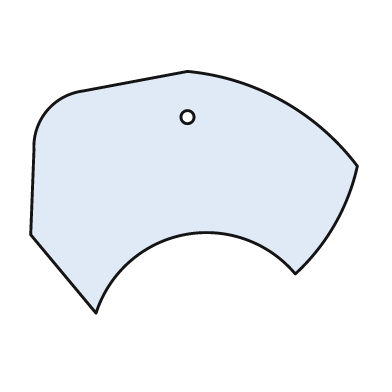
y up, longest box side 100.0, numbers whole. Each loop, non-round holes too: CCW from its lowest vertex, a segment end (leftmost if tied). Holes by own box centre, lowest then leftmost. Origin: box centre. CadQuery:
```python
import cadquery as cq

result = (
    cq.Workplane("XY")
    .moveTo(-30.0, -37.0)
    .threePointArc((-3.0, -13.0), (31.0, -25.0))
    .threePointArc((43.0, -10.0), (50.0, 8.0))
    .threePointArc((27.0, 28.0), (-2.0, 37.0))
    .lineTo(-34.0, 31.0)
    .threePointArc((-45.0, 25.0), (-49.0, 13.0))
    .lineTo(-50.0, -13.0)
    .close()
    .moveTo(-2.0, 23.0)
    .circle(2.0)
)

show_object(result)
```